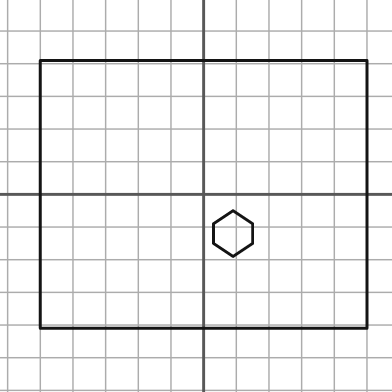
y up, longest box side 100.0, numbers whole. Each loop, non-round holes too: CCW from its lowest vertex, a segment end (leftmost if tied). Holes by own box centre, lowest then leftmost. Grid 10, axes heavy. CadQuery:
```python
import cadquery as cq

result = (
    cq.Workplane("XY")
    .moveTo(-50.0, -41.0)
    .lineTo(50.0, -41.0)
    .lineTo(50.0, 41.0)
    .lineTo(-50.0, 41.0)
    .close()
    .moveTo(9.0, -19.0)
    .lineTo(15.0, -15.0)
    .lineTo(15.0, -9.0)
    .lineTo(9.0, -5.0)
    .lineTo(3.0, -9.0)
    .lineTo(3.0, -15.0)
    .close()
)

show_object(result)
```